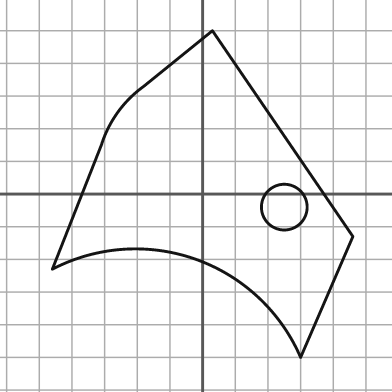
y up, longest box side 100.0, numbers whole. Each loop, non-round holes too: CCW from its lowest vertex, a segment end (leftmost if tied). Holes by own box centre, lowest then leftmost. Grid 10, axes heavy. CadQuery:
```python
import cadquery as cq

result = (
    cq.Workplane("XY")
    .moveTo(30.0, -50.0)
    .lineTo(46.0, -13.0)
    .lineTo(3.0, 50.0)
    .lineTo(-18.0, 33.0)
    .threePointArc((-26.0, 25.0), (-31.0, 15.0))
    .lineTo(-46.0, -23.0)
    .threePointArc((-2.0, -20.0), (30.0, -50.0))
    .close()
    .moveTo(25.0, -4.0)
    .circle(7.0)
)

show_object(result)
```